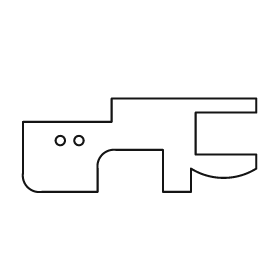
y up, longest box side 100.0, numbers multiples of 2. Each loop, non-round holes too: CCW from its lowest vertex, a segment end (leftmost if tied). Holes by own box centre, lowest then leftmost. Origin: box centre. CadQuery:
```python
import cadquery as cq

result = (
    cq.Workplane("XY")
    .moveTo(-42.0, -20.0)
    .lineTo(-18.0, -20.0)
    .lineTo(-18.0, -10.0)
    .threePointArc((-16.0, -4.0), (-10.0, -2.0))
    .lineTo(10.0, -2.0)
    .lineTo(10.0, -20.0)
    .lineTo(22.0, -20.0)
    .lineTo(22.0, -10.0)
    .threePointArc((36.0, -14.0), (50.0, -10.0))
    .lineTo(50.0, -4.0)
    .lineTo(24.0, -4.0)
    .lineTo(24.0, 14.0)
    .lineTo(50.0, 14.0)
    .lineTo(50.0, 20.0)
    .lineTo(-12.0, 20.0)
    .lineTo(-12.0, 10.0)
    .lineTo(-50.0, 10.0)
    .lineTo(-50.0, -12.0)
    .threePointArc((-48.0, -18.0), (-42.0, -20.0))
    .close()
    .moveTo(-34.0, 2.0)
    .circle(2.0)
    .moveTo(-26.0, 2.0)
    .circle(2.0)
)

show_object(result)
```